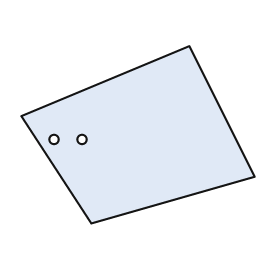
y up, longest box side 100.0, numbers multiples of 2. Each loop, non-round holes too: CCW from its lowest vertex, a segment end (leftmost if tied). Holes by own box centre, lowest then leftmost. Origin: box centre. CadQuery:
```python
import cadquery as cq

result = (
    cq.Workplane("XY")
    .moveTo(-20.0, -38.0)
    .lineTo(50.0, -18.0)
    .lineTo(22.0, 38.0)
    .lineTo(-50.0, 8.0)
    .close()
    .moveTo(-36.0, -2.0)
    .circle(2.0)
    .moveTo(-24.0, -2.0)
    .circle(2.0)
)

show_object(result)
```